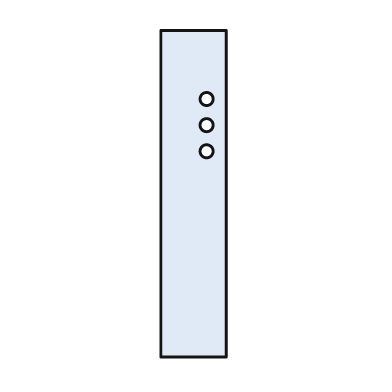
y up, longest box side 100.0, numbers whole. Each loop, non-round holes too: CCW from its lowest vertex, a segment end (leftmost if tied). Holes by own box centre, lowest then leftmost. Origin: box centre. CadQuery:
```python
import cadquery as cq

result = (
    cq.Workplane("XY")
    .moveTo(-10.0, -50.0)
    .lineTo(10.0, -50.0)
    .lineTo(10.0, 50.0)
    .lineTo(-10.0, 50.0)
    .close()
    .moveTo(4.0, 13.0)
    .circle(2.0)
    .moveTo(4.0, 21.0)
    .circle(2.0)
    .moveTo(4.0, 29.0)
    .circle(2.0)
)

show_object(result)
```